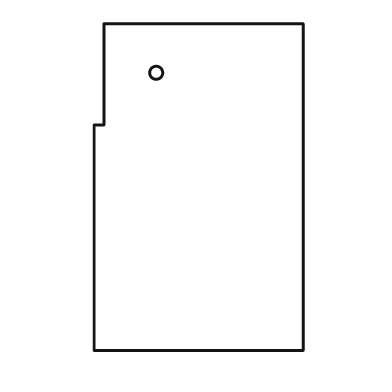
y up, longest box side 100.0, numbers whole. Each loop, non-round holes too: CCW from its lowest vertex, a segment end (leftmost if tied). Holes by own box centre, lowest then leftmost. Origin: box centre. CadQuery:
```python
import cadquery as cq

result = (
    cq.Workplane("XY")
    .moveTo(-32.0, -50.0)
    .lineTo(32.0, -50.0)
    .lineTo(32.0, 50.0)
    .lineTo(-29.0, 50.0)
    .lineTo(-29.0, 19.0)
    .lineTo(-32.0, 19.0)
    .close()
    .moveTo(-13.0, 35.0)
    .circle(2.0)
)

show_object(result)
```